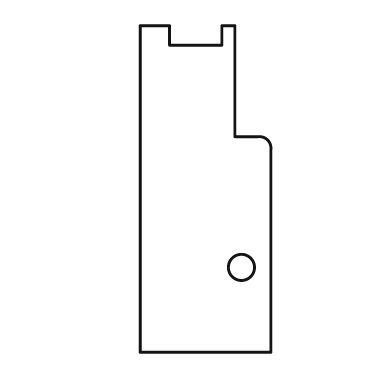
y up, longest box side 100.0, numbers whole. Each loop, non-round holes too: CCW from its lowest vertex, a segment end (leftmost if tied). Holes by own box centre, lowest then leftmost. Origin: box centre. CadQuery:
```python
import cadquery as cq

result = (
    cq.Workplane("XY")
    .moveTo(-20.0, -50.0)
    .lineTo(20.0, -50.0)
    .lineTo(20.0, 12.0)
    .threePointArc((19.0, 15.0), (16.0, 16.0))
    .lineTo(9.0, 16.0)
    .lineTo(9.0, 50.0)
    .lineTo(5.0, 50.0)
    .lineTo(5.0, 44.0)
    .lineTo(-11.0, 44.0)
    .lineTo(-11.0, 50.0)
    .lineTo(-20.0, 50.0)
    .close()
    .moveTo(11.0, -24.0)
    .circle(4.0)
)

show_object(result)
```